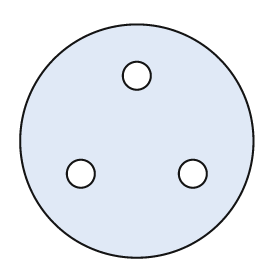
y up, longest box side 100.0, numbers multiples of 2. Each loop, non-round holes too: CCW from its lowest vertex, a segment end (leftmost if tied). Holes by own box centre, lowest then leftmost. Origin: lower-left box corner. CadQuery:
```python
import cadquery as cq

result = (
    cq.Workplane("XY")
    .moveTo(50.0, 50.0)
    .circle(50.0)
    .moveTo(26.0, 36.0)
    .circle(6.0)
    .moveTo(74.0, 36.0)
    .circle(6.0)
    .moveTo(50.0, 78.0)
    .circle(6.0)
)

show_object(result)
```